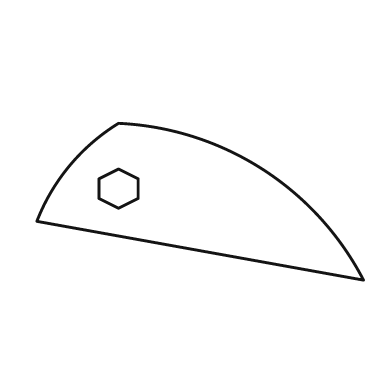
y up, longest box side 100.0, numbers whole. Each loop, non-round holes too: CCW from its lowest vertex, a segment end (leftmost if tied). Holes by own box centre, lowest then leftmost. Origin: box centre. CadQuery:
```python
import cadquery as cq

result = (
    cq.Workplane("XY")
    .moveTo(50.0, -24.0)
    .threePointArc((19.0, 10.0), (-25.0, 24.0))
    .threePointArc((-40.0, 11.0), (-50.0, -6.0))
    .close()
    .moveTo(-25.0, -2.0)
    .lineTo(-19.0, 1.0)
    .lineTo(-19.0, 7.0)
    .lineTo(-25.0, 10.0)
    .lineTo(-31.0, 7.0)
    .lineTo(-31.0, 1.0)
    .close()
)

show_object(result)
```